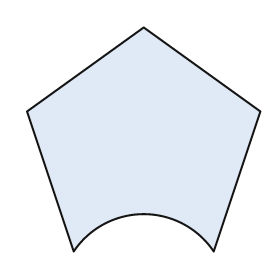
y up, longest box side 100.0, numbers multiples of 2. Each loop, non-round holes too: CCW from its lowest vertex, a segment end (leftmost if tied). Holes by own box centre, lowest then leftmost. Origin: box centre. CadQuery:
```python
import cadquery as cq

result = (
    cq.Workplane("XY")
    .moveTo(-30.0, -48.0)
    .threePointArc((0.0, -32.0), (30.0, -48.0))
    .lineTo(50.0, 12.0)
    .lineTo(0.0, 48.0)
    .lineTo(-50.0, 12.0)
    .close()
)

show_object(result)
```